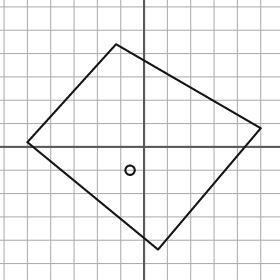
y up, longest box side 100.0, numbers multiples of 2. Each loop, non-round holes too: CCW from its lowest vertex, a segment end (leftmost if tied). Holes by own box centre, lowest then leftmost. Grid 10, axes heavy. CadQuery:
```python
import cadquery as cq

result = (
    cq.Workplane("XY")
    .moveTo(6.0, -44.0)
    .lineTo(50.0, 8.0)
    .lineTo(-12.0, 44.0)
    .lineTo(-50.0, 2.0)
    .close()
    .moveTo(-6.0, -10.0)
    .circle(2.0)
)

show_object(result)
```